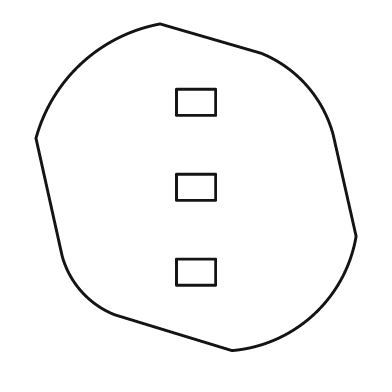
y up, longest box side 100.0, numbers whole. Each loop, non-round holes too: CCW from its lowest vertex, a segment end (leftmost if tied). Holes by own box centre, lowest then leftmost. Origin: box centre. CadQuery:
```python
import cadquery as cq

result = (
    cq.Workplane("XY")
    .moveTo(11.0, -50.0)
    .threePointArc((36.0, -39.0), (49.0, -15.0))
    .lineTo(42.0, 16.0)
    .threePointArc((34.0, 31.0), (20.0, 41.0))
    .lineTo(-11.0, 50.0)
    .threePointArc((-35.0, 38.0), (-49.0, 15.0))
    .lineTo(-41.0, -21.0)
    .threePointArc((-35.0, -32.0), (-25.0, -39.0))
    .close()
    .moveTo(-6.0, -30.0)
    .lineTo(6.0, -30.0)
    .lineTo(6.0, -22.0)
    .lineTo(-6.0, -22.0)
    .close()
    .moveTo(-6.0, -4.0)
    .lineTo(6.0, -4.0)
    .lineTo(6.0, 4.0)
    .lineTo(-6.0, 4.0)
    .close()
    .moveTo(-6.0, 22.0)
    .lineTo(6.0, 22.0)
    .lineTo(6.0, 30.0)
    .lineTo(-6.0, 30.0)
    .close()
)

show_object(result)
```